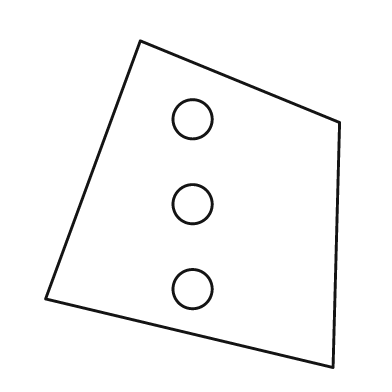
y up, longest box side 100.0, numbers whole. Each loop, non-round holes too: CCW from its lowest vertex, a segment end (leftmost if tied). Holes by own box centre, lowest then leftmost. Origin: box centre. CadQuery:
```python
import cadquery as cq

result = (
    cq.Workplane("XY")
    .moveTo(43.0, -50.0)
    .lineTo(45.0, 25.0)
    .lineTo(-16.0, 50.0)
    .lineTo(-45.0, -29.0)
    .close()
    .moveTo(0.0, -26.0)
    .circle(6.0)
    .moveTo(0.0, 0.0)
    .circle(6.0)
    .moveTo(0.0, 26.0)
    .circle(6.0)
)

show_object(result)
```